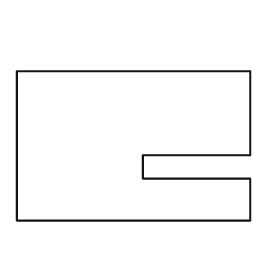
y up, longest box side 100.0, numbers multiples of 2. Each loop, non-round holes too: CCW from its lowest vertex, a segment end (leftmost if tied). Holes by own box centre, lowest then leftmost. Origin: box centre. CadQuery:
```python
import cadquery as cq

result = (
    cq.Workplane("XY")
    .moveTo(-50.0, -32.0)
    .lineTo(50.0, -32.0)
    .lineTo(50.0, -14.0)
    .lineTo(4.0, -14.0)
    .lineTo(4.0, -4.0)
    .lineTo(50.0, -4.0)
    .lineTo(50.0, 32.0)
    .lineTo(-50.0, 32.0)
    .close()
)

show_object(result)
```